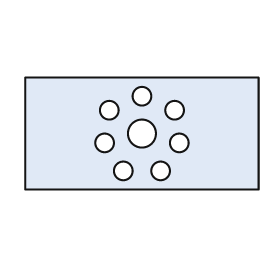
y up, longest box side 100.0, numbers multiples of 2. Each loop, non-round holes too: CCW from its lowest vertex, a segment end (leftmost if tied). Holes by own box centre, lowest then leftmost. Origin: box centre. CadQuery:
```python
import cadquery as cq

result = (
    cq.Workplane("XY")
    .moveTo(-50.0, -24.0)
    .lineTo(50.0, -24.0)
    .lineTo(50.0, 24.0)
    .lineTo(-50.0, 24.0)
    .close()
    .moveTo(-8.0, -16.0)
    .circle(4.0)
    .moveTo(8.0, -16.0)
    .circle(4.0)
    .moveTo(-16.0, -4.0)
    .circle(4.0)
    .moveTo(16.0, -4.0)
    .circle(4.0)
    .moveTo(0.0, 0.0)
    .circle(6.0)
    .moveTo(-14.0, 10.0)
    .circle(4.0)
    .moveTo(14.0, 10.0)
    .circle(4.0)
    .moveTo(0.0, 16.0)
    .circle(4.0)
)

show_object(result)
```